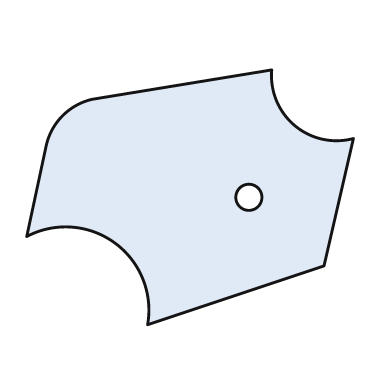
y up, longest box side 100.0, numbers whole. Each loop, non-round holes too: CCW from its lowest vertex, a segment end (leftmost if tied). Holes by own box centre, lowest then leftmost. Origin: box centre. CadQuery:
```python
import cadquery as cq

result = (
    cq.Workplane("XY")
    .moveTo(-13.0, -39.0)
    .lineTo(41.0, -21.0)
    .lineTo(50.0, 18.0)
    .threePointArc((32.0, 22.0), (25.0, 39.0))
    .lineTo(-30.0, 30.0)
    .threePointArc((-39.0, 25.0), (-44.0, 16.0))
    .lineTo(-50.0, -12.0)
    .threePointArc((-23.0, -14.0), (-13.0, -39.0))
    .close()
    .moveTo(18.0, 0.0)
    .circle(4.0)
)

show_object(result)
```